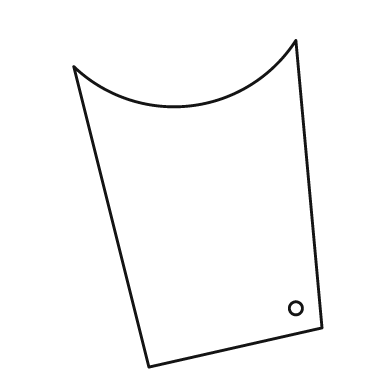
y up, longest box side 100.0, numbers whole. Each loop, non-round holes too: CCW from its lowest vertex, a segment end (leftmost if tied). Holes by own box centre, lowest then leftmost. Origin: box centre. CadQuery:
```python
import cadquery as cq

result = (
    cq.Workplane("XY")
    .moveTo(-15.0, -50.0)
    .lineTo(38.0, -38.0)
    .lineTo(30.0, 50.0)
    .threePointArc((-2.0, 30.0), (-38.0, 42.0))
    .close()
    .moveTo(30.0, -32.0)
    .circle(2.0)
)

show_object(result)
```